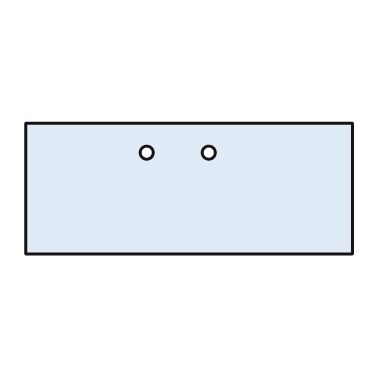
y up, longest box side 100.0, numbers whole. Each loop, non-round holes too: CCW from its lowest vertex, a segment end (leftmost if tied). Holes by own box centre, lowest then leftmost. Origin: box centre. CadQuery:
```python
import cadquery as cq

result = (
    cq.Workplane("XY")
    .moveTo(-50.0, -20.0)
    .lineTo(50.0, -20.0)
    .lineTo(50.0, 20.0)
    .lineTo(-50.0, 20.0)
    .close()
    .moveTo(-13.0, 11.0)
    .circle(2.0)
    .moveTo(6.0, 11.0)
    .circle(2.0)
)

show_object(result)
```